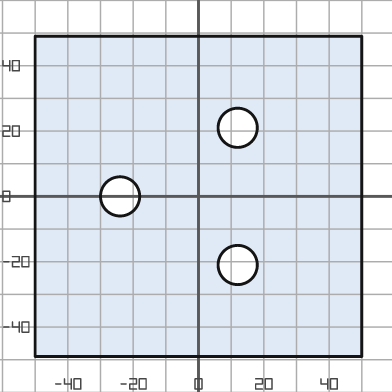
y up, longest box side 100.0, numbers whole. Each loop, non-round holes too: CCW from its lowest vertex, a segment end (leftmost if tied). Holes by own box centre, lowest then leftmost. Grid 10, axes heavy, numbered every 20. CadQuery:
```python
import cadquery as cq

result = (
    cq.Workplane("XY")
    .moveTo(-50.0, -49.0)
    .lineTo(50.0, -49.0)
    .lineTo(50.0, 49.0)
    .lineTo(-50.0, 49.0)
    .close()
    .moveTo(12.0, -21.0)
    .circle(6.0)
    .moveTo(-24.0, 0.0)
    .circle(6.0)
    .moveTo(12.0, 21.0)
    .circle(6.0)
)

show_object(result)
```